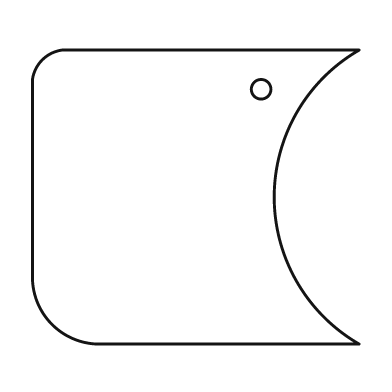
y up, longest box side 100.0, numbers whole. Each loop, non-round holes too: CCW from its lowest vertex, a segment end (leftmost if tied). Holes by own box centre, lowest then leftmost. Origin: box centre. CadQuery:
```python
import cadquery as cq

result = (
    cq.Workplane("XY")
    .moveTo(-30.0, -45.0)
    .lineTo(50.0, -45.0)
    .threePointArc((24.0, 0.0), (50.0, 45.0))
    .lineTo(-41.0, 45.0)
    .threePointArc((-47.0, 42.0), (-50.0, 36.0))
    .lineTo(-50.0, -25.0)
    .threePointArc((-44.0, -39.0), (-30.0, -45.0))
    .close()
    .moveTo(20.0, 33.0)
    .circle(3.0)
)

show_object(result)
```